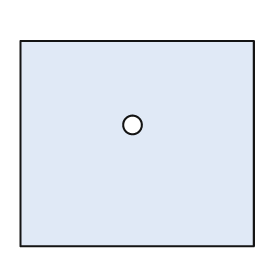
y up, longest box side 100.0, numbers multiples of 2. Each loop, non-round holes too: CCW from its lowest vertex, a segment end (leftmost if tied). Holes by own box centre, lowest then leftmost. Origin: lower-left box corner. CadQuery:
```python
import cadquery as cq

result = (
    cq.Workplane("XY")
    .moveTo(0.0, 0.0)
    .lineTo(100.0, 0.0)
    .lineTo(100.0, 88.0)
    .lineTo(0.0, 88.0)
    .close()
    .moveTo(48.0, 52.0)
    .circle(4.0)
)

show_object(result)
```